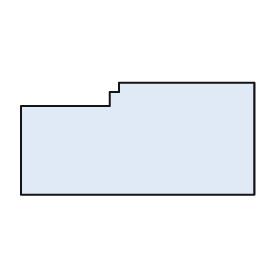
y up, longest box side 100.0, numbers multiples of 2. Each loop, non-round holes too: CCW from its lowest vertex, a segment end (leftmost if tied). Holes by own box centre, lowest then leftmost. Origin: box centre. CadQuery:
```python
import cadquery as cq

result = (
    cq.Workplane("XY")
    .moveTo(-50.0, -24.0)
    .lineTo(50.0, -24.0)
    .lineTo(50.0, 24.0)
    .lineTo(-8.0, 24.0)
    .lineTo(-8.0, 20.0)
    .lineTo(-12.0, 20.0)
    .lineTo(-12.0, 14.0)
    .lineTo(-50.0, 14.0)
    .close()
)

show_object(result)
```